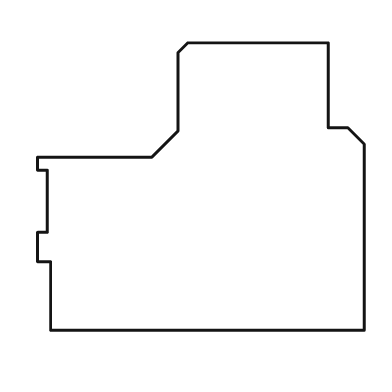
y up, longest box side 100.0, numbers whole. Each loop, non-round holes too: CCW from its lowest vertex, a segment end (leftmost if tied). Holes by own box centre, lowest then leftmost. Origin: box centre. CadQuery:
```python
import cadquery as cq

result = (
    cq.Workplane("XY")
    .moveTo(-46.0, -44.0)
    .lineTo(50.0, -44.0)
    .lineTo(50.0, 13.0)
    .lineTo(45.0, 18.0)
    .lineTo(39.0, 18.0)
    .lineTo(39.0, 44.0)
    .lineTo(-4.0, 44.0)
    .lineTo(-7.0, 41.0)
    .lineTo(-7.0, 17.0)
    .lineTo(-15.0, 9.0)
    .lineTo(-50.0, 9.0)
    .lineTo(-50.0, 5.0)
    .lineTo(-47.0, 5.0)
    .lineTo(-47.0, -14.0)
    .lineTo(-50.0, -14.0)
    .lineTo(-50.0, -23.0)
    .lineTo(-46.0, -23.0)
    .close()
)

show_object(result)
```